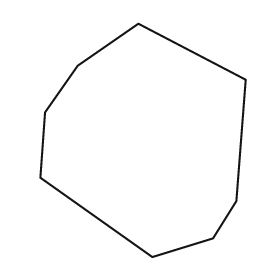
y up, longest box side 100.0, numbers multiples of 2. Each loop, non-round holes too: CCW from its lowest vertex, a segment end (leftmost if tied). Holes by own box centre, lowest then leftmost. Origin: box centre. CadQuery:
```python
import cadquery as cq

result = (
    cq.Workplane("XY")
    .moveTo(4.0, -50.0)
    .lineTo(30.0, -42.0)
    .lineTo(40.0, -26.0)
    .lineTo(44.0, 26.0)
    .lineTo(-2.0, 50.0)
    .lineTo(-28.0, 32.0)
    .lineTo(-42.0, 12.0)
    .lineTo(-44.0, -16.0)
    .close()
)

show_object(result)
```